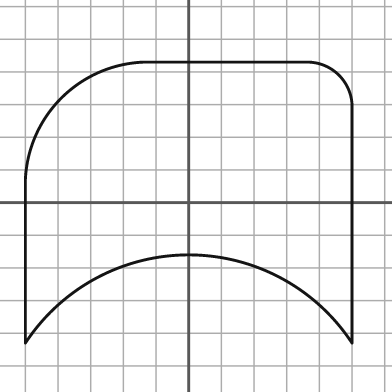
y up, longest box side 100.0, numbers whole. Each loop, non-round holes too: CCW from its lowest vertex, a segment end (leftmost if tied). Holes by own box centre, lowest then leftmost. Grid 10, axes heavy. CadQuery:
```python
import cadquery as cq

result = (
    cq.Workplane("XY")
    .moveTo(-50.0, -43.0)
    .threePointArc((0.0, -16.0), (50.0, -43.0))
    .lineTo(50.0, 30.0)
    .threePointArc((46.0, 39.0), (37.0, 43.0))
    .lineTo(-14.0, 43.0)
    .threePointArc((-39.0, 32.0), (-50.0, 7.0))
    .close()
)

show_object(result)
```